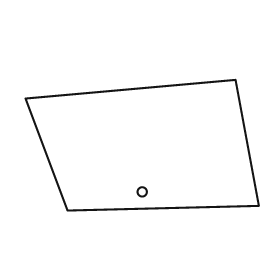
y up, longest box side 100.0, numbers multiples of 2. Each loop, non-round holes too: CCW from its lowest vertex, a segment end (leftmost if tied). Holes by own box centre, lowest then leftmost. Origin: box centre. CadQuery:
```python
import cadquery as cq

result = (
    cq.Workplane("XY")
    .moveTo(-32.0, -28.0)
    .lineTo(50.0, -26.0)
    .lineTo(40.0, 28.0)
    .lineTo(-50.0, 20.0)
    .close()
    .moveTo(0.0, -20.0)
    .circle(2.0)
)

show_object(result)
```